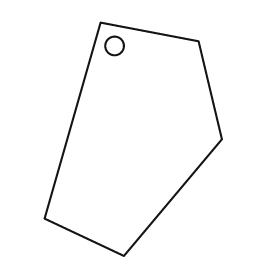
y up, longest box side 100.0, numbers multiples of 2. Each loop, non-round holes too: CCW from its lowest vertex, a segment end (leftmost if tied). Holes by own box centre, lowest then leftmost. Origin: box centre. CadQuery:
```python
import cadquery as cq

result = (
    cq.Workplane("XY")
    .moveTo(-4.0, -50.0)
    .lineTo(38.0, 0.0)
    .lineTo(28.0, 42.0)
    .lineTo(-14.0, 50.0)
    .lineTo(-38.0, -34.0)
    .close()
    .moveTo(-8.0, 40.0)
    .circle(4.0)
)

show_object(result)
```